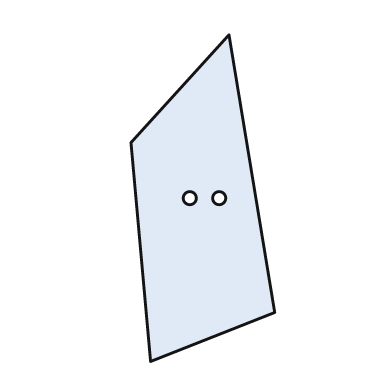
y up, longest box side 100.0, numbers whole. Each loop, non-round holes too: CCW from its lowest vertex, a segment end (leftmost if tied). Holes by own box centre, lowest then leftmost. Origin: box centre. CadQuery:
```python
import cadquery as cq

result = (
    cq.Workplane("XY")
    .moveTo(-16.0, -50.0)
    .lineTo(22.0, -35.0)
    .lineTo(8.0, 50.0)
    .lineTo(-22.0, 17.0)
    .close()
    .moveTo(-4.0, 0.0)
    .circle(2.0)
    .moveTo(5.0, 0.0)
    .circle(2.0)
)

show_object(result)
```